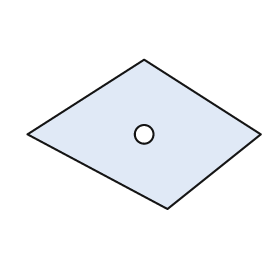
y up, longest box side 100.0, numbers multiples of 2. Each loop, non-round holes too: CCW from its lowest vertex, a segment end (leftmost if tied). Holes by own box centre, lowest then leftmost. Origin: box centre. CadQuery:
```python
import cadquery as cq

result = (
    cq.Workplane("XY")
    .moveTo(10.0, -32.0)
    .lineTo(50.0, 0.0)
    .lineTo(0.0, 32.0)
    .lineTo(-50.0, 0.0)
    .close()
    .moveTo(0.0, 0.0)
    .circle(4.0)
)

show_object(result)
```